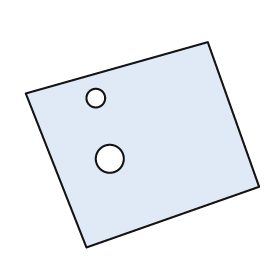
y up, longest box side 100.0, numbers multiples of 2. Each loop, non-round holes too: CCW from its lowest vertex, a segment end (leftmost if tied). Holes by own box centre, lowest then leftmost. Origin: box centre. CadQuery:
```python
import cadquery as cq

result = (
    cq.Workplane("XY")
    .moveTo(-24.0, -44.0)
    .lineTo(50.0, -18.0)
    .lineTo(28.0, 44.0)
    .lineTo(-50.0, 22.0)
    .close()
    .moveTo(-14.0, -6.0)
    .circle(6.0)
    .moveTo(-20.0, 20.0)
    .circle(4.0)
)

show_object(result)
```